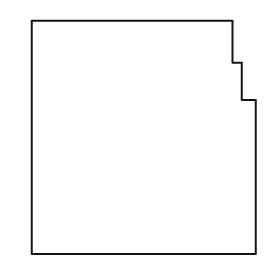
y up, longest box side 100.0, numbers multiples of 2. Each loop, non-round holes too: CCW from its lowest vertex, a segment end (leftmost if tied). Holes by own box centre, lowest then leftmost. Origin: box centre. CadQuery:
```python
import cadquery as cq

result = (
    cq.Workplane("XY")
    .moveTo(-48.0, -50.0)
    .lineTo(48.0, -50.0)
    .lineTo(48.0, 16.0)
    .lineTo(42.0, 16.0)
    .lineTo(42.0, 32.0)
    .lineTo(38.0, 32.0)
    .lineTo(38.0, 50.0)
    .lineTo(-48.0, 50.0)
    .close()
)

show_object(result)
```